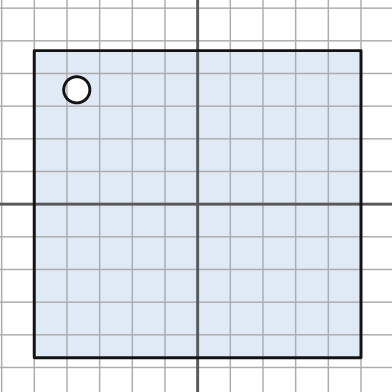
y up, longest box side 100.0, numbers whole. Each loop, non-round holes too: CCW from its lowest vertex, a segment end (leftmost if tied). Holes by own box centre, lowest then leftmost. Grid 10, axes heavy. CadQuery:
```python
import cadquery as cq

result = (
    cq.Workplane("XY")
    .moveTo(-50.0, -47.0)
    .lineTo(50.0, -47.0)
    .lineTo(50.0, 47.0)
    .lineTo(-50.0, 47.0)
    .close()
    .moveTo(-37.0, 35.0)
    .circle(4.0)
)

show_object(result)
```